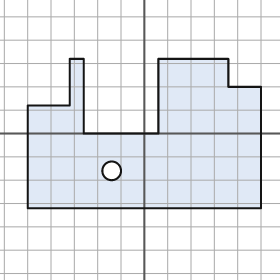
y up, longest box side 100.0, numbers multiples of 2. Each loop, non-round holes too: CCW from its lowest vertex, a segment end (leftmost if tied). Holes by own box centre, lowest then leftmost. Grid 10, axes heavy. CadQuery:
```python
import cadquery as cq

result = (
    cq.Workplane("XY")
    .moveTo(-50.0, -32.0)
    .lineTo(50.0, -32.0)
    .lineTo(50.0, 20.0)
    .lineTo(36.0, 20.0)
    .lineTo(36.0, 32.0)
    .lineTo(6.0, 32.0)
    .lineTo(6.0, 0.0)
    .lineTo(-26.0, 0.0)
    .lineTo(-26.0, 32.0)
    .lineTo(-32.0, 32.0)
    .lineTo(-32.0, 12.0)
    .lineTo(-50.0, 12.0)
    .close()
    .moveTo(-14.0, -16.0)
    .circle(4.0)
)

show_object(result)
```